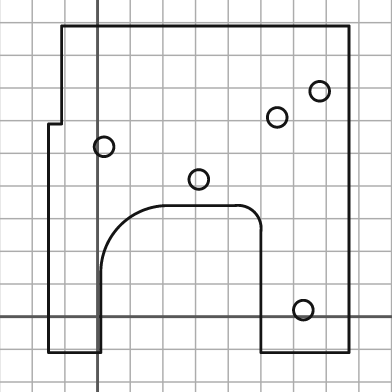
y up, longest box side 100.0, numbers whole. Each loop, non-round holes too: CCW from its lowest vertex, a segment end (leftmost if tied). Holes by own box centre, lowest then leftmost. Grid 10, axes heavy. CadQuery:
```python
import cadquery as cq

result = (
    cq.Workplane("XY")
    .moveTo(-15.0, -11.0)
    .lineTo(1.0, -11.0)
    .lineTo(1.0, 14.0)
    .threePointArc((7.0, 28.0), (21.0, 34.0))
    .lineTo(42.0, 34.0)
    .threePointArc((48.0, 32.0), (50.0, 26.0))
    .lineTo(50.0, -11.0)
    .lineTo(77.0, -11.0)
    .lineTo(77.0, 89.0)
    .lineTo(-11.0, 89.0)
    .lineTo(-11.0, 59.0)
    .lineTo(-15.0, 59.0)
    .close()
    .moveTo(63.0, 2.0)
    .circle(3.0)
    .moveTo(31.0, 42.0)
    .circle(3.0)
    .moveTo(2.0, 52.0)
    .circle(3.0)
    .moveTo(55.0, 61.0)
    .circle(3.0)
    .moveTo(68.0, 69.0)
    .circle(3.0)
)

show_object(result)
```